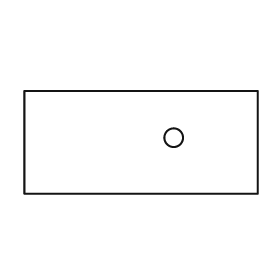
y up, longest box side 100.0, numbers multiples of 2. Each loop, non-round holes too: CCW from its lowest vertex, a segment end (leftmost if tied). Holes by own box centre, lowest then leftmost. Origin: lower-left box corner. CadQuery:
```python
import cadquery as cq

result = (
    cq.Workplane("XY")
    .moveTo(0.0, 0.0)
    .lineTo(100.0, 0.0)
    .lineTo(100.0, 44.0)
    .lineTo(0.0, 44.0)
    .close()
    .moveTo(64.0, 24.0)
    .circle(4.0)
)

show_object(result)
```